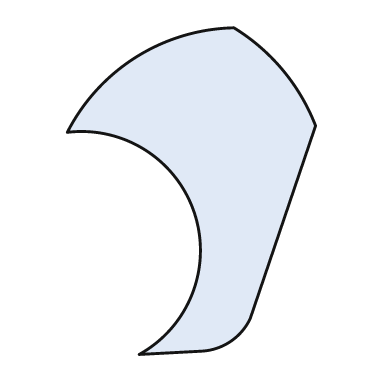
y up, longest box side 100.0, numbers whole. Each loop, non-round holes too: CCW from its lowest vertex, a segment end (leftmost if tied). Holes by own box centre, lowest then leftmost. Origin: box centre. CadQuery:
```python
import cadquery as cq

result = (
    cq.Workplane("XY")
    .moveTo(-16.0, -50.0)
    .lineTo(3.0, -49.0)
    .threePointArc((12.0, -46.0), (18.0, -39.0))
    .lineTo(38.0, 20.0)
    .threePointArc((28.0, 37.0), (13.0, 50.0))
    .threePointArc((-17.0, 41.0), (-38.0, 18.0))
    .threePointArc((1.0, -7.0), (-16.0, -50.0))
    .close()
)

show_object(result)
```